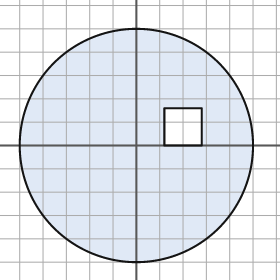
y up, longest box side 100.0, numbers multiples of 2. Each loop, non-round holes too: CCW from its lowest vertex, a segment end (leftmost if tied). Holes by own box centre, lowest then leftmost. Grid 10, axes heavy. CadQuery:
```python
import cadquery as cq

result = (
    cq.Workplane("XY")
    .moveTo(0.0, 0.0)
    .circle(50.0)
    .moveTo(12.0, 0.0)
    .lineTo(28.0, 0.0)
    .lineTo(28.0, 16.0)
    .lineTo(12.0, 16.0)
    .close()
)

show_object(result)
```